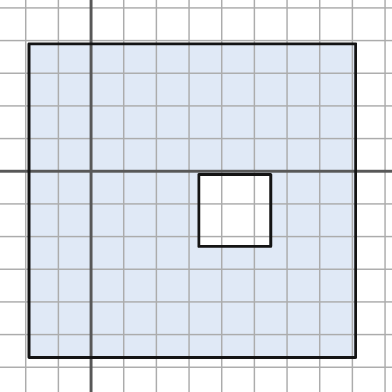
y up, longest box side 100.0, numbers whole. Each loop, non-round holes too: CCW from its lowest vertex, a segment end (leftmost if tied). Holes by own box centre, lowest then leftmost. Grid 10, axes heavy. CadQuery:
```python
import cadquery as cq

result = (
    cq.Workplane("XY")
    .moveTo(-19.0, -57.0)
    .lineTo(81.0, -57.0)
    .lineTo(81.0, 39.0)
    .lineTo(-19.0, 39.0)
    .close()
    .moveTo(33.0, -23.0)
    .lineTo(55.0, -23.0)
    .lineTo(55.0, -1.0)
    .lineTo(33.0, -1.0)
    .close()
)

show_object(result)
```